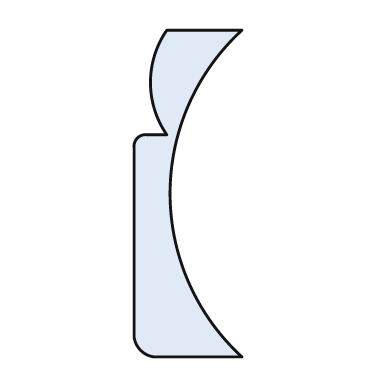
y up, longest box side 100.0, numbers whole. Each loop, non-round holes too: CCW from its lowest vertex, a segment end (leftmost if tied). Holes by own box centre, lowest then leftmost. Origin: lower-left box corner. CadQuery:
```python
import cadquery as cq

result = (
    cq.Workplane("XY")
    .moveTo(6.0, 0.0)
    .lineTo(33.0, 0.0)
    .threePointArc((11.0, 50.0), (33.0, 100.0))
    .lineTo(10.0, 100.0)
    .threePointArc((5.0, 84.0), (10.0, 68.0))
    .lineTo(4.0, 68.0)
    .threePointArc((1.0, 67.0), (0.0, 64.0))
    .lineTo(0.0, 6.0)
    .threePointArc((2.0, 2.0), (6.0, 0.0))
    .close()
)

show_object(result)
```